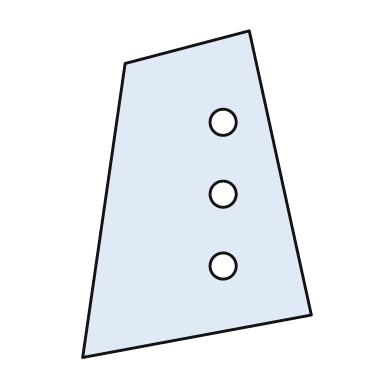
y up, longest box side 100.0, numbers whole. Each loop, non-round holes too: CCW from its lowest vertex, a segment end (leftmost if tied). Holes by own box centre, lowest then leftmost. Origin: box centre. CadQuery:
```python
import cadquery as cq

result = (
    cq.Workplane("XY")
    .moveTo(-35.0, -50.0)
    .lineTo(35.0, -37.0)
    .lineTo(16.0, 50.0)
    .lineTo(-22.0, 40.0)
    .close()
    .moveTo(8.0, -22.0)
    .circle(4.0)
    .moveTo(8.0, 0.0)
    .circle(4.0)
    .moveTo(8.0, 22.0)
    .circle(4.0)
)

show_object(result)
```